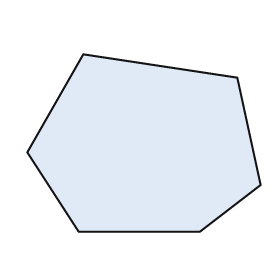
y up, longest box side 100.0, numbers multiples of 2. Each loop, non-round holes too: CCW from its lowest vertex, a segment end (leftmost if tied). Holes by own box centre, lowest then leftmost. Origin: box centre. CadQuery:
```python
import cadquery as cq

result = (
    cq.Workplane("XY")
    .moveTo(-28.0, -38.0)
    .lineTo(24.0, -38.0)
    .lineTo(50.0, -18.0)
    .lineTo(40.0, 28.0)
    .lineTo(-26.0, 38.0)
    .lineTo(-50.0, -4.0)
    .close()
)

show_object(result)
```